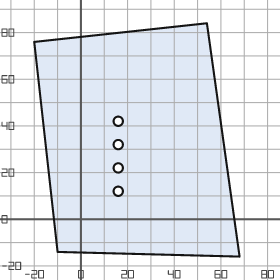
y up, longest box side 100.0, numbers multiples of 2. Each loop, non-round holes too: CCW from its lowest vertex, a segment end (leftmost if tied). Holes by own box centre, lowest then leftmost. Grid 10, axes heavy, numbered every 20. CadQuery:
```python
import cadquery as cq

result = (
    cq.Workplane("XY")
    .moveTo(68.0, -16.0)
    .lineTo(54.0, 84.0)
    .lineTo(-20.0, 76.0)
    .lineTo(-10.0, -14.0)
    .close()
    .moveTo(16.0, 12.0)
    .circle(2.0)
    .moveTo(16.0, 22.0)
    .circle(2.0)
    .moveTo(16.0, 32.0)
    .circle(2.0)
    .moveTo(16.0, 42.0)
    .circle(2.0)
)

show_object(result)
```